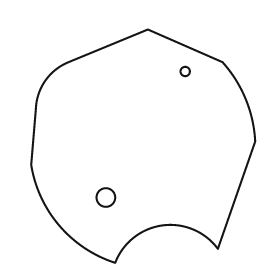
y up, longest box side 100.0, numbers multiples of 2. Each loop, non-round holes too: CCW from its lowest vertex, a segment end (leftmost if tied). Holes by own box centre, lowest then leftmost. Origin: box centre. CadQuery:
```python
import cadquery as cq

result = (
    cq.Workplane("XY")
    .moveTo(-12.0, -50.0)
    .threePointArc((8.0, -34.0), (32.0, -44.0))
    .lineTo(48.0, 2.0)
    .threePointArc((44.0, 20.0), (34.0, 36.0))
    .lineTo(2.0, 50.0)
    .lineTo(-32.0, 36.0)
    .threePointArc((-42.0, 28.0), (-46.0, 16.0))
    .lineTo(-48.0, -8.0)
    .threePointArc((-36.0, -34.0), (-12.0, -50.0))
    .close()
    .moveTo(-16.0, -22.0)
    .circle(4.0)
    .moveTo(18.0, 32.0)
    .circle(2.0)
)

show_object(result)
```